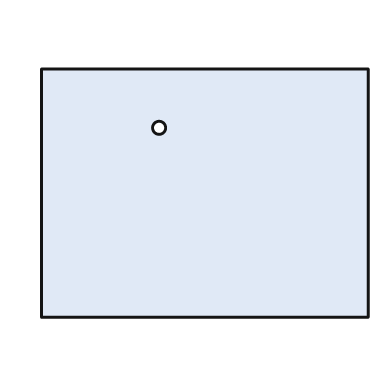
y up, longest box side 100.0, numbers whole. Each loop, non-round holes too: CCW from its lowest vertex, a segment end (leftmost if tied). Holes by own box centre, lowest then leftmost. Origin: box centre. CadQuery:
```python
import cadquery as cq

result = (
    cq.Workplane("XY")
    .moveTo(-50.0, -38.0)
    .lineTo(50.0, -38.0)
    .lineTo(50.0, 38.0)
    .lineTo(-50.0, 38.0)
    .close()
    .moveTo(-14.0, 20.0)
    .circle(2.0)
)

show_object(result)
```